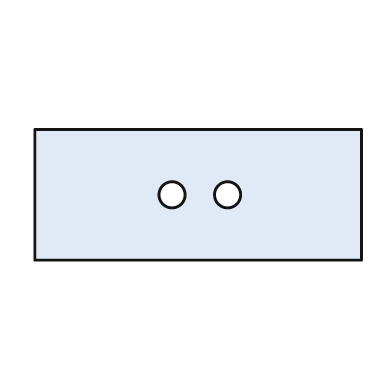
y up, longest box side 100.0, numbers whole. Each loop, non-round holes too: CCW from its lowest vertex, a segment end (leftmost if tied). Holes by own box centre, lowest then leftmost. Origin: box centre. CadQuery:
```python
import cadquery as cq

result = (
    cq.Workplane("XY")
    .moveTo(-50.0, -20.0)
    .lineTo(50.0, -20.0)
    .lineTo(50.0, 20.0)
    .lineTo(-50.0, 20.0)
    .close()
    .moveTo(-8.0, 0.0)
    .circle(4.0)
    .moveTo(9.0, 0.0)
    .circle(4.0)
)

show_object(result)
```